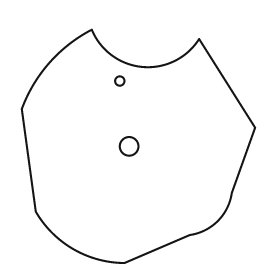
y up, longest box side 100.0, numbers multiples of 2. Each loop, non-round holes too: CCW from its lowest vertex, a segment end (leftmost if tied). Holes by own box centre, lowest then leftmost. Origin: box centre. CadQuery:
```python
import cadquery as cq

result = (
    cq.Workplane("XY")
    .moveTo(-6.0, -50.0)
    .lineTo(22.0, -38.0)
    .threePointArc((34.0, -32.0), (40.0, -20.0))
    .lineTo(50.0, 8.0)
    .lineTo(26.0, 46.0)
    .threePointArc((2.0, 34.0), (-20.0, 50.0))
    .threePointArc((-38.0, 36.0), (-50.0, 16.0))
    .lineTo(-44.0, -28.0)
    .threePointArc((-28.0, -44.0), (-6.0, -50.0))
    .close()
    .moveTo(-4.0, 0.0)
    .circle(4.0)
    .moveTo(-8.0, 28.0)
    .circle(2.0)
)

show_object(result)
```